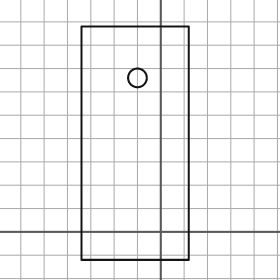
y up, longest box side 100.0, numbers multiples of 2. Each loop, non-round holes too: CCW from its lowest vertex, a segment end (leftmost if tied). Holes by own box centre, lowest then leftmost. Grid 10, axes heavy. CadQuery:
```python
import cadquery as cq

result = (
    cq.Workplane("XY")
    .moveTo(-34.0, -12.0)
    .lineTo(12.0, -12.0)
    .lineTo(12.0, 88.0)
    .lineTo(-34.0, 88.0)
    .close()
    .moveTo(-10.0, 66.0)
    .circle(4.0)
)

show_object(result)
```